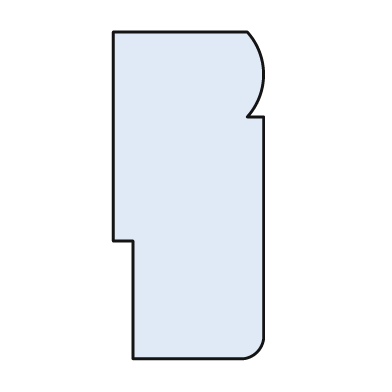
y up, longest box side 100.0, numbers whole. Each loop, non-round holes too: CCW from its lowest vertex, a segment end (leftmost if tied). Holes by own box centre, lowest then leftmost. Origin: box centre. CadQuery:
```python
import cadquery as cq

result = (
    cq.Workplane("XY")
    .moveTo(-17.0, -50.0)
    .lineTo(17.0, -50.0)
    .threePointArc((21.0, -48.0), (23.0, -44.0))
    .lineTo(23.0, 24.0)
    .lineTo(18.0, 24.0)
    .threePointArc((23.0, 37.0), (18.0, 50.0))
    .lineTo(-23.0, 50.0)
    .lineTo(-23.0, -14.0)
    .lineTo(-17.0, -14.0)
    .close()
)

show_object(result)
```